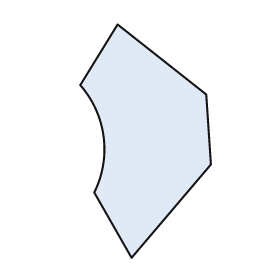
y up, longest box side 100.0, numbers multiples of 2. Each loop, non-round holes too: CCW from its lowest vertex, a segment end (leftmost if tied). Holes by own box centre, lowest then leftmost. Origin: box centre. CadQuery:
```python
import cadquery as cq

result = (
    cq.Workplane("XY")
    .moveTo(-6.0, -50.0)
    .lineTo(28.0, -10.0)
    .lineTo(26.0, 20.0)
    .lineTo(-12.0, 50.0)
    .lineTo(-28.0, 24.0)
    .threePointArc((-18.0, 2.0), (-22.0, -22.0))
    .close()
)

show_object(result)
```